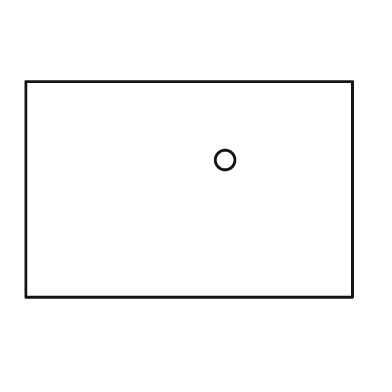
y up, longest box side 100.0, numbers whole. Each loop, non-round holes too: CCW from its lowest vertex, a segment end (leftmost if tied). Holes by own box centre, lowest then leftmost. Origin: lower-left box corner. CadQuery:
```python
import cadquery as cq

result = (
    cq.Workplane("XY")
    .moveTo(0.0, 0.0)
    .lineTo(100.0, 0.0)
    .lineTo(100.0, 66.0)
    .lineTo(0.0, 66.0)
    .close()
    .moveTo(61.0, 42.0)
    .circle(3.0)
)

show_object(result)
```